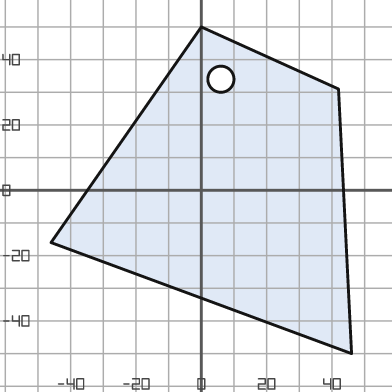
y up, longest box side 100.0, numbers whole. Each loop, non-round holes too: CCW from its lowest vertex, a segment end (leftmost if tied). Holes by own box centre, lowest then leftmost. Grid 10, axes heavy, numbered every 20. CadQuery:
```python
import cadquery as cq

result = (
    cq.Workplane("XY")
    .moveTo(46.0, -50.0)
    .lineTo(42.0, 31.0)
    .lineTo(0.0, 50.0)
    .lineTo(-46.0, -16.0)
    .close()
    .moveTo(6.0, 34.0)
    .circle(4.0)
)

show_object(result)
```